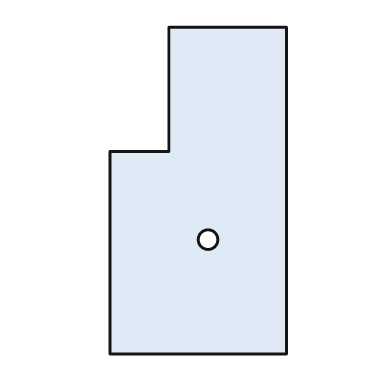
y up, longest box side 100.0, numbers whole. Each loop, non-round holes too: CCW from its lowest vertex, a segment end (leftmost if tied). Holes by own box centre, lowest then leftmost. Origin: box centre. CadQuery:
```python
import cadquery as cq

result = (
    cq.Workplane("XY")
    .moveTo(-27.0, -50.0)
    .lineTo(27.0, -50.0)
    .lineTo(27.0, 50.0)
    .lineTo(-9.0, 50.0)
    .lineTo(-9.0, 12.0)
    .lineTo(-27.0, 12.0)
    .close()
    .moveTo(3.0, -15.0)
    .circle(3.0)
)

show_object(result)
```